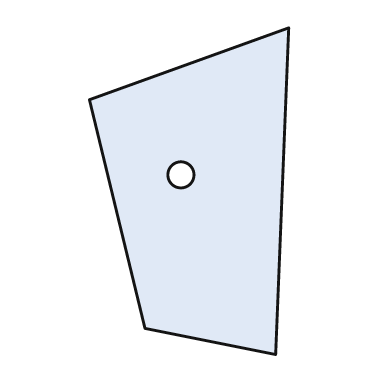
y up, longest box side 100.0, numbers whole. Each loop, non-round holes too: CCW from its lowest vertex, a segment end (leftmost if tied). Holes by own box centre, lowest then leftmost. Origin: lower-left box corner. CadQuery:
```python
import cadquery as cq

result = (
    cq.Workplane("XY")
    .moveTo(57.0, 0.0)
    .lineTo(61.0, 100.0)
    .lineTo(0.0, 78.0)
    .lineTo(17.0, 8.0)
    .close()
    .moveTo(28.0, 55.0)
    .circle(4.0)
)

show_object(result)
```